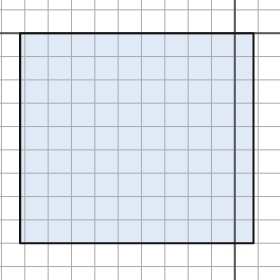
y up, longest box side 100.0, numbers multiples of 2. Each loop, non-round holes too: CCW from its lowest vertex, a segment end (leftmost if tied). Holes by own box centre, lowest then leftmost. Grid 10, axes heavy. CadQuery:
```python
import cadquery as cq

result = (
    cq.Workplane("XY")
    .moveTo(-92.0, -90.0)
    .lineTo(8.0, -90.0)
    .lineTo(8.0, 0.0)
    .lineTo(-92.0, 0.0)
    .close()
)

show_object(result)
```